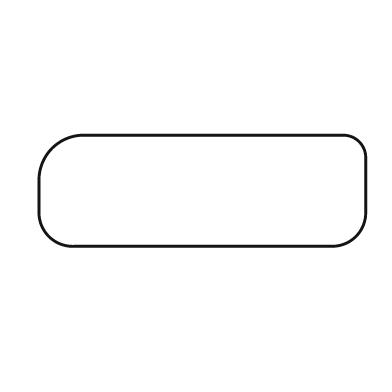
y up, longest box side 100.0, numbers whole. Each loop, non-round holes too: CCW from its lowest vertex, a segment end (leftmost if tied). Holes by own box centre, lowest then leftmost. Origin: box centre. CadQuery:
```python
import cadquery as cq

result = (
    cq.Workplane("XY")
    .moveTo(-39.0, -17.0)
    .lineTo(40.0, -17.0)
    .threePointArc((47.0, -14.0), (50.0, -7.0))
    .lineTo(50.0, 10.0)
    .threePointArc((48.0, 15.0), (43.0, 17.0))
    .lineTo(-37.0, 17.0)
    .threePointArc((-46.0, 13.0), (-50.0, 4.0))
    .lineTo(-50.0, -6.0)
    .threePointArc((-47.0, -14.0), (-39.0, -17.0))
    .close()
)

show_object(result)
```